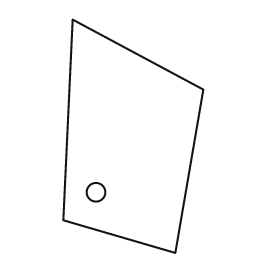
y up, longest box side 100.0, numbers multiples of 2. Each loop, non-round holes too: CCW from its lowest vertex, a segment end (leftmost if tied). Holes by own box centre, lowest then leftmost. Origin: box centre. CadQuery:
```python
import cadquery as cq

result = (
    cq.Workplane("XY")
    .moveTo(18.0, -50.0)
    .lineTo(30.0, 20.0)
    .lineTo(-26.0, 50.0)
    .lineTo(-30.0, -36.0)
    .close()
    .moveTo(-16.0, -24.0)
    .circle(4.0)
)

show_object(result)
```